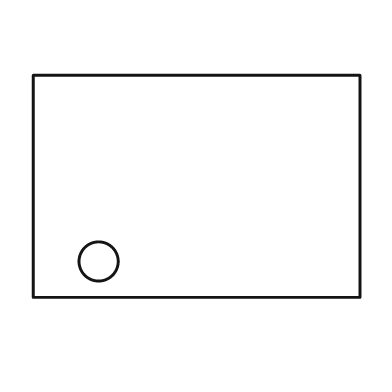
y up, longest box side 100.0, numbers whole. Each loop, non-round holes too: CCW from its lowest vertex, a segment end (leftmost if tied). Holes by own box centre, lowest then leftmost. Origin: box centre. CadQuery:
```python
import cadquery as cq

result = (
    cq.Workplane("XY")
    .moveTo(-50.0, -34.0)
    .lineTo(50.0, -34.0)
    .lineTo(50.0, 34.0)
    .lineTo(-50.0, 34.0)
    .close()
    .moveTo(-30.0, -23.0)
    .circle(6.0)
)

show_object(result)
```